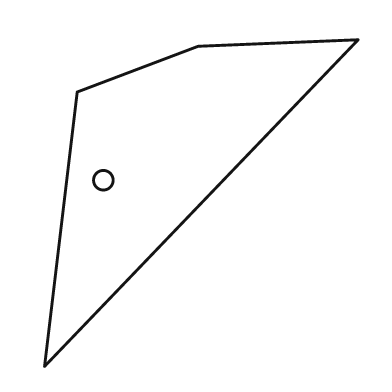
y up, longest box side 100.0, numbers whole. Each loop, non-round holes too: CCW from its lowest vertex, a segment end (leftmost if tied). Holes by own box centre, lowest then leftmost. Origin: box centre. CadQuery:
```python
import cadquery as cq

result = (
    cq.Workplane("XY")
    .moveTo(-48.0, -50.0)
    .lineTo(48.0, 50.0)
    .lineTo(-1.0, 48.0)
    .lineTo(-38.0, 34.0)
    .close()
    .moveTo(-30.0, 7.0)
    .circle(3.0)
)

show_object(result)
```